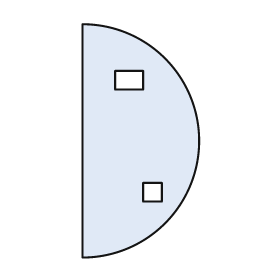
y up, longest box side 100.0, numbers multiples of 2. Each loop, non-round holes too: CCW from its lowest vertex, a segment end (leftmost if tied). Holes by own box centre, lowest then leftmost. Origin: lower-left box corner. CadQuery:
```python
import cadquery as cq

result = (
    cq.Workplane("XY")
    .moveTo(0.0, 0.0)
    .threePointArc((50.0, 50.0), (0.0, 100.0))
    .close()
    .moveTo(26.0, 24.0)
    .lineTo(34.0, 24.0)
    .lineTo(34.0, 32.0)
    .lineTo(26.0, 32.0)
    .close()
    .moveTo(14.0, 72.0)
    .lineTo(26.0, 72.0)
    .lineTo(26.0, 80.0)
    .lineTo(14.0, 80.0)
    .close()
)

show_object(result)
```